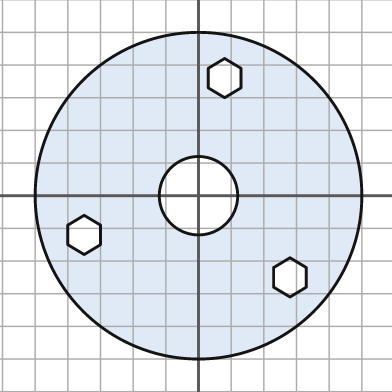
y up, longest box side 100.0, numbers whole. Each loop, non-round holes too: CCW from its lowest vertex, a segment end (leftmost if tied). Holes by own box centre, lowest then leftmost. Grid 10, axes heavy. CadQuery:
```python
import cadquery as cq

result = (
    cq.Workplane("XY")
    .moveTo(0.0, 0.0)
    .circle(50.0)
    .moveTo(28.0, -31.0)
    .lineTo(33.0, -28.0)
    .lineTo(33.0, -22.0)
    .lineTo(28.0, -19.0)
    .lineTo(23.0, -22.0)
    .lineTo(23.0, -28.0)
    .close()
    .moveTo(-35.0, -18.0)
    .lineTo(-30.0, -15.0)
    .lineTo(-30.0, -9.0)
    .lineTo(-35.0, -6.0)
    .lineTo(-40.0, -9.0)
    .lineTo(-40.0, -15.0)
    .close()
    .moveTo(0.0, 0.0)
    .circle(12.0)
    .moveTo(8.0, 30.0)
    .lineTo(13.0, 33.0)
    .lineTo(13.0, 39.0)
    .lineTo(8.0, 42.0)
    .lineTo(3.0, 39.0)
    .lineTo(3.0, 33.0)
    .close()
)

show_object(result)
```